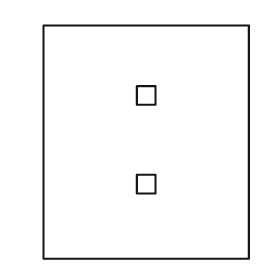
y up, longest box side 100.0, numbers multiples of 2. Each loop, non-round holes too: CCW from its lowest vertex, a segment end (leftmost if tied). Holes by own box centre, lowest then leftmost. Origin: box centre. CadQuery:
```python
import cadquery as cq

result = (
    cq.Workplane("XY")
    .moveTo(-44.0, -50.0)
    .lineTo(44.0, -50.0)
    .lineTo(44.0, 50.0)
    .lineTo(-44.0, 50.0)
    .close()
    .moveTo(-4.0, -22.0)
    .lineTo(4.0, -22.0)
    .lineTo(4.0, -14.0)
    .lineTo(-4.0, -14.0)
    .close()
    .moveTo(-4.0, 16.0)
    .lineTo(4.0, 16.0)
    .lineTo(4.0, 24.0)
    .lineTo(-4.0, 24.0)
    .close()
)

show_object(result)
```